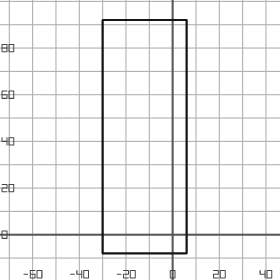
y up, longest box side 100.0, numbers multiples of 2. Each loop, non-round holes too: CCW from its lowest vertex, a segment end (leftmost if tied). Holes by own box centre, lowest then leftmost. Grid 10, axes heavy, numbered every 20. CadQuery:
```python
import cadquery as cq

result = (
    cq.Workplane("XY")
    .moveTo(-30.0, -8.0)
    .lineTo(6.0, -8.0)
    .lineTo(6.0, 92.0)
    .lineTo(-30.0, 92.0)
    .close()
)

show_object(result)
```